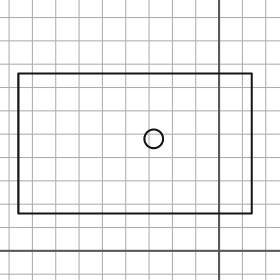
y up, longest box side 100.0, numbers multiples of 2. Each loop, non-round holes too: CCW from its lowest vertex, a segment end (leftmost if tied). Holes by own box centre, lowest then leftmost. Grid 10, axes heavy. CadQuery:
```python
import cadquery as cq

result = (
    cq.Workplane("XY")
    .moveTo(-86.0, 16.0)
    .lineTo(14.0, 16.0)
    .lineTo(14.0, 76.0)
    .lineTo(-86.0, 76.0)
    .close()
    .moveTo(-28.0, 48.0)
    .circle(4.0)
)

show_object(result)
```